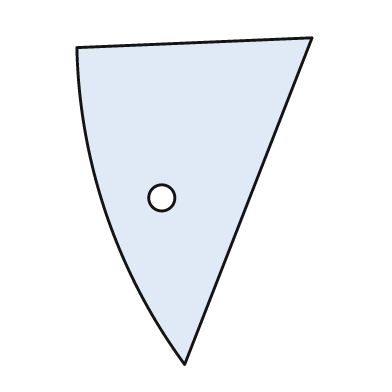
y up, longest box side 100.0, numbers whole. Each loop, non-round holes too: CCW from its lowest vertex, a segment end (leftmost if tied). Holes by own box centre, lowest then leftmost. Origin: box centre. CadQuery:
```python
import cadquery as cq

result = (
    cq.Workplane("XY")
    .moveTo(-3.0, -50.0)
    .lineTo(36.0, 50.0)
    .lineTo(-36.0, 47.0)
    .threePointArc((-27.0, -4.0), (-3.0, -50.0))
    .close()
    .moveTo(-10.0, 1.0)
    .circle(4.0)
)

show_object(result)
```